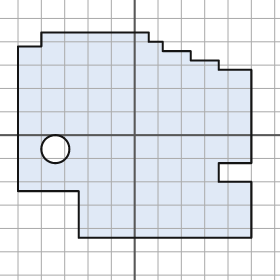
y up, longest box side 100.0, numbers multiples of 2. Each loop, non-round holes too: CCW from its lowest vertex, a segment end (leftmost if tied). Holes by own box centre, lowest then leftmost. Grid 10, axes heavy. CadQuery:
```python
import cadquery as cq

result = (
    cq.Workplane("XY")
    .moveTo(-24.0, -44.0)
    .lineTo(50.0, -44.0)
    .lineTo(50.0, -20.0)
    .lineTo(36.0, -20.0)
    .lineTo(36.0, -12.0)
    .lineTo(50.0, -12.0)
    .lineTo(50.0, 28.0)
    .lineTo(36.0, 28.0)
    .lineTo(36.0, 32.0)
    .lineTo(24.0, 32.0)
    .lineTo(24.0, 36.0)
    .lineTo(12.0, 36.0)
    .lineTo(12.0, 40.0)
    .lineTo(6.0, 40.0)
    .lineTo(6.0, 44.0)
    .lineTo(-40.0, 44.0)
    .lineTo(-40.0, 38.0)
    .lineTo(-50.0, 38.0)
    .lineTo(-50.0, -24.0)
    .lineTo(-24.0, -24.0)
    .close()
    .moveTo(-34.0, -6.0)
    .circle(6.0)
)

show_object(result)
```